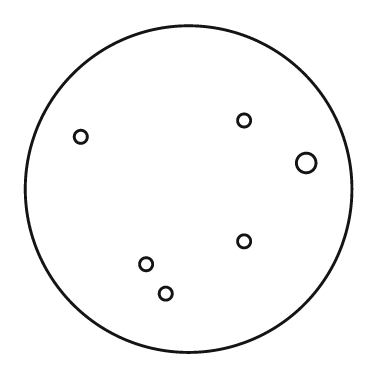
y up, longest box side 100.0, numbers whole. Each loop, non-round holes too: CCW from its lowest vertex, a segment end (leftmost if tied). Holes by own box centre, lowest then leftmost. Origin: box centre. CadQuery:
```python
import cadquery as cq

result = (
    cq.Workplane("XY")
    .moveTo(0.0, 0.0)
    .circle(50.0)
    .moveTo(-7.0, -32.0)
    .circle(2.0)
    .moveTo(-13.0, -23.0)
    .circle(2.0)
    .moveTo(17.0, -16.0)
    .circle(2.0)
    .moveTo(36.0, 8.0)
    .circle(3.0)
    .moveTo(-33.0, 16.0)
    .circle(2.0)
    .moveTo(17.0, 21.0)
    .circle(2.0)
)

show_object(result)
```